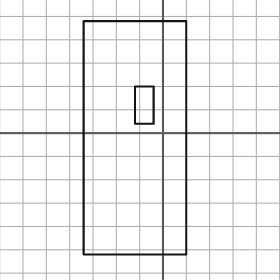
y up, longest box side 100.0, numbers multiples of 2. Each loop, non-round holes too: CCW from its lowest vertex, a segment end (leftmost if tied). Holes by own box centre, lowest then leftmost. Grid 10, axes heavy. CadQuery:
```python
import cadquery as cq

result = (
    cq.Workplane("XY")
    .moveTo(-34.0, -52.0)
    .lineTo(10.0, -52.0)
    .lineTo(10.0, 48.0)
    .lineTo(-34.0, 48.0)
    .close()
    .moveTo(-12.0, 4.0)
    .lineTo(-4.0, 4.0)
    .lineTo(-4.0, 20.0)
    .lineTo(-12.0, 20.0)
    .close()
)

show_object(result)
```